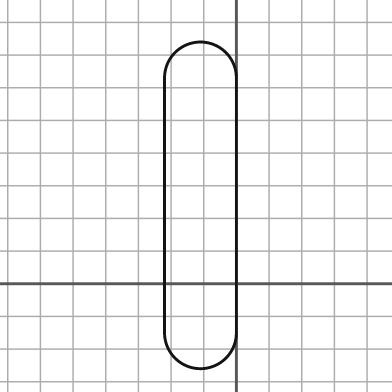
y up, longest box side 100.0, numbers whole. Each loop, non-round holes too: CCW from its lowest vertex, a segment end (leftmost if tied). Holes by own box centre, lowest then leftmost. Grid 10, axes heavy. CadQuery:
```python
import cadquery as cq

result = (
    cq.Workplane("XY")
    .moveTo(-22.0, -15.0)
    .threePointArc((-11.0, -26.0), (0.0, -15.0))
    .lineTo(0.0, 63.0)
    .threePointArc((-11.0, 74.0), (-22.0, 63.0))
    .close()
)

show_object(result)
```